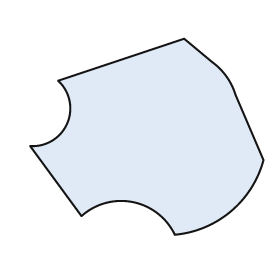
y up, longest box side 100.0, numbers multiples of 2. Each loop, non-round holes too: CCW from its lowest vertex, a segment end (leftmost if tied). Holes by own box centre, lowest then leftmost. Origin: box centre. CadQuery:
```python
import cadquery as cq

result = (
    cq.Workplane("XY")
    .moveTo(12.0, -42.0)
    .threePointArc((36.0, -32.0), (50.0, -10.0))
    .lineTo(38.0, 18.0)
    .threePointArc((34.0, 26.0), (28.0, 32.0))
    .lineTo(16.0, 42.0)
    .lineTo(-38.0, 24.0)
    .threePointArc((-34.0, 6.0), (-50.0, -4.0))
    .lineTo(-28.0, -34.0)
    .threePointArc((-6.0, -28.0), (12.0, -42.0))
    .close()
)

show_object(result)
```